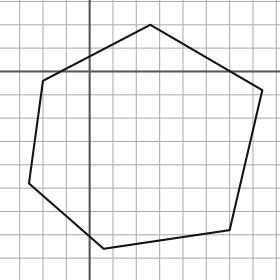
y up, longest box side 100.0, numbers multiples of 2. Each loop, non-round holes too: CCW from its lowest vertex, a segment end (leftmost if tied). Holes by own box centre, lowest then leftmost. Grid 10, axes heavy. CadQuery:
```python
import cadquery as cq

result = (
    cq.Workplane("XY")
    .moveTo(6.0, -76.0)
    .lineTo(60.0, -68.0)
    .lineTo(74.0, -8.0)
    .lineTo(26.0, 20.0)
    .lineTo(-20.0, -4.0)
    .lineTo(-26.0, -48.0)
    .close()
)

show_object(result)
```